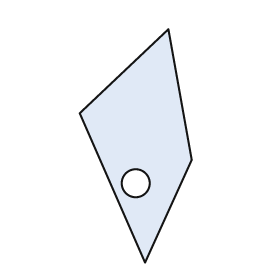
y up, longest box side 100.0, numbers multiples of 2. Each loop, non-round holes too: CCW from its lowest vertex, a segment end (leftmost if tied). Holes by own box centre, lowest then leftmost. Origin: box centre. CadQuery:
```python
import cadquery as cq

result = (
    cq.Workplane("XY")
    .moveTo(4.0, -50.0)
    .lineTo(24.0, -6.0)
    .lineTo(14.0, 50.0)
    .lineTo(-24.0, 14.0)
    .close()
    .moveTo(0.0, -16.0)
    .circle(6.0)
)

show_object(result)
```